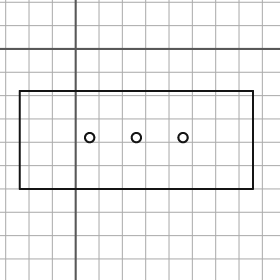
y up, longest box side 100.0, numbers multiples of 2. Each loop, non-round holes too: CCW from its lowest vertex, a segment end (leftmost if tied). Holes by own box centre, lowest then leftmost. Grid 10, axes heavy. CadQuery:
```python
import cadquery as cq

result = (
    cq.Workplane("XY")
    .moveTo(-24.0, -60.0)
    .lineTo(76.0, -60.0)
    .lineTo(76.0, -18.0)
    .lineTo(-24.0, -18.0)
    .close()
    .moveTo(6.0, -38.0)
    .circle(2.0)
    .moveTo(26.0, -38.0)
    .circle(2.0)
    .moveTo(46.0, -38.0)
    .circle(2.0)
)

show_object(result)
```